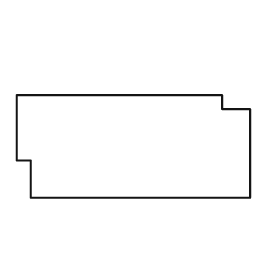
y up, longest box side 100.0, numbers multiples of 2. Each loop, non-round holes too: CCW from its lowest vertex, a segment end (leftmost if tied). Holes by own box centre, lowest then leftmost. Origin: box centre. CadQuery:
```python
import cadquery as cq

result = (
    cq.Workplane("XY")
    .moveTo(-44.0, -22.0)
    .lineTo(50.0, -22.0)
    .lineTo(50.0, 16.0)
    .lineTo(38.0, 16.0)
    .lineTo(38.0, 22.0)
    .lineTo(-50.0, 22.0)
    .lineTo(-50.0, -6.0)
    .lineTo(-44.0, -6.0)
    .close()
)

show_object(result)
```